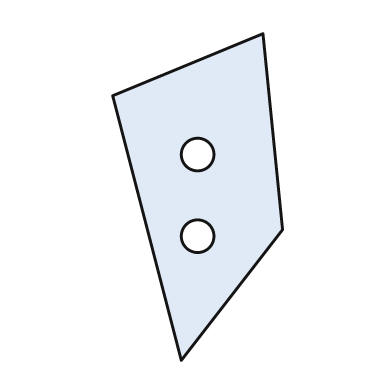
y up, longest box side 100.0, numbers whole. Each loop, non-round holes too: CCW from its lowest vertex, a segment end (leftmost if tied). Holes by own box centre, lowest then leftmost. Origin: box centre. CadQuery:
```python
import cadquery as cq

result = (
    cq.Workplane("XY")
    .moveTo(-5.0, -50.0)
    .lineTo(26.0, -10.0)
    .lineTo(20.0, 50.0)
    .lineTo(-26.0, 31.0)
    .close()
    .moveTo(0.0, -12.0)
    .circle(5.0)
    .moveTo(0.0, 13.0)
    .circle(5.0)
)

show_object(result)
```